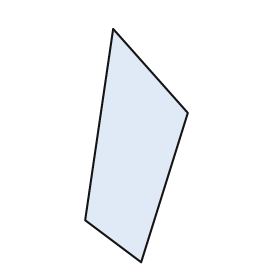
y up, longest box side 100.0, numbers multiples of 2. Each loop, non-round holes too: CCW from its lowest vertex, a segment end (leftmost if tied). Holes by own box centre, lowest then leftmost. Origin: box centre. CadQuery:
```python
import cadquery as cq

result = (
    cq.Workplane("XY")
    .moveTo(2.0, -50.0)
    .lineTo(22.0, 14.0)
    .lineTo(-10.0, 50.0)
    .lineTo(-22.0, -32.0)
    .close()
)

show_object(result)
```